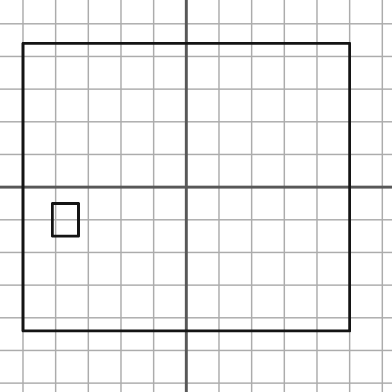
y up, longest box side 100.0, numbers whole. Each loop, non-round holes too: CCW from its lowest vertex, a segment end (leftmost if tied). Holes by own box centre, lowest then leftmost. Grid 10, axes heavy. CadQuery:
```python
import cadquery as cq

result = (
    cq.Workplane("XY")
    .moveTo(-50.0, -44.0)
    .lineTo(50.0, -44.0)
    .lineTo(50.0, 44.0)
    .lineTo(-50.0, 44.0)
    .close()
    .moveTo(-41.0, -15.0)
    .lineTo(-33.0, -15.0)
    .lineTo(-33.0, -5.0)
    .lineTo(-41.0, -5.0)
    .close()
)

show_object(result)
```